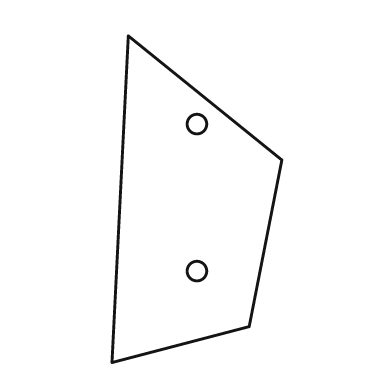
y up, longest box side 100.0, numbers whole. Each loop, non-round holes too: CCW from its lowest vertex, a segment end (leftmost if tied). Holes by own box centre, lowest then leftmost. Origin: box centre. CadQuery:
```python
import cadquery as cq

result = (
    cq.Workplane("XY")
    .moveTo(-26.0, -50.0)
    .lineTo(16.0, -39.0)
    .lineTo(26.0, 12.0)
    .lineTo(-21.0, 50.0)
    .close()
    .moveTo(0.0, -22.0)
    .circle(3.0)
    .moveTo(0.0, 23.0)
    .circle(3.0)
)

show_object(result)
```